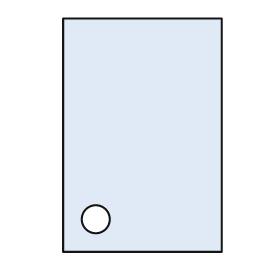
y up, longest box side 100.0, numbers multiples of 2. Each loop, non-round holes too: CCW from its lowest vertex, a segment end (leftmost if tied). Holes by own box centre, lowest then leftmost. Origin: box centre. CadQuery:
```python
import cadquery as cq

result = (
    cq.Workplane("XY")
    .moveTo(-34.0, -50.0)
    .lineTo(34.0, -50.0)
    .lineTo(34.0, 50.0)
    .lineTo(-34.0, 50.0)
    .close()
    .moveTo(-20.0, -36.0)
    .circle(6.0)
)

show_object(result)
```